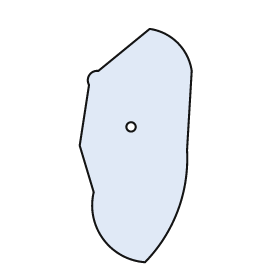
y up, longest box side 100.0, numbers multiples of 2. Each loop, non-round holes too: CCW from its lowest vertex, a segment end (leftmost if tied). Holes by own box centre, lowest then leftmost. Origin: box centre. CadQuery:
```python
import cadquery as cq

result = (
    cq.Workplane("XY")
    .moveTo(4.0, -50.0)
    .threePointArc((18.0, -28.0), (22.0, -2.0))
    .lineTo(24.0, 32.0)
    .threePointArc((18.0, 44.0), (6.0, 50.0))
    .lineTo(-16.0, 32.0)
    .threePointArc((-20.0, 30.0), (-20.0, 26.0))
    .lineTo(-24.0, 0.0)
    .lineTo(-18.0, -20.0)
    .threePointArc((-14.0, -40.0), (4.0, -50.0))
    .close()
    .moveTo(-2.0, 8.0)
    .circle(2.0)
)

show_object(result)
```